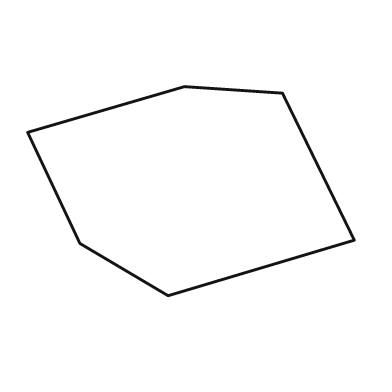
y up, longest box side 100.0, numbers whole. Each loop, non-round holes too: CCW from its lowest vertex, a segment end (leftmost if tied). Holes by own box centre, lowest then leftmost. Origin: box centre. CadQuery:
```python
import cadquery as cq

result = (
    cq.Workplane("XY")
    .moveTo(-7.0, -32.0)
    .lineTo(50.0, -15.0)
    .lineTo(28.0, 30.0)
    .lineTo(-2.0, 32.0)
    .lineTo(-50.0, 18.0)
    .lineTo(-34.0, -16.0)
    .close()
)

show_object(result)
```